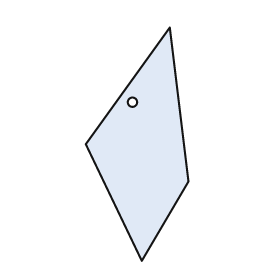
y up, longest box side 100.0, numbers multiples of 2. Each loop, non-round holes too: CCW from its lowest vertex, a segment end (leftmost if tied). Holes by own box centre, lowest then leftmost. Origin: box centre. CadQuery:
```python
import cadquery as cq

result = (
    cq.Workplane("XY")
    .moveTo(2.0, -50.0)
    .lineTo(22.0, -16.0)
    .lineTo(14.0, 50.0)
    .lineTo(-22.0, 0.0)
    .close()
    .moveTo(-2.0, 18.0)
    .circle(2.0)
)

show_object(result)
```